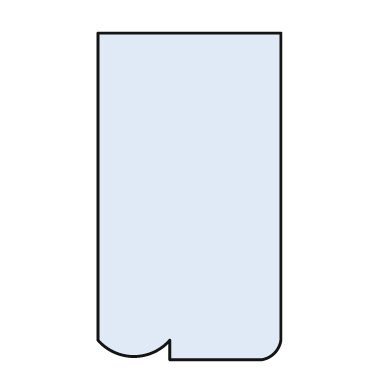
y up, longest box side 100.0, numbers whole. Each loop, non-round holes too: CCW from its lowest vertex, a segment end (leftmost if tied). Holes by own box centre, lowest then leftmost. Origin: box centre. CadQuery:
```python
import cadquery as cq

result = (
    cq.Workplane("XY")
    .moveTo(-6.0, -50.0)
    .lineTo(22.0, -50.0)
    .threePointArc((26.0, -48.0), (28.0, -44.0))
    .lineTo(28.0, 50.0)
    .lineTo(-28.0, 50.0)
    .lineTo(-28.0, -44.0)
    .threePointArc((-17.0, -49.0), (-6.0, -44.0))
    .close()
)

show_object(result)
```